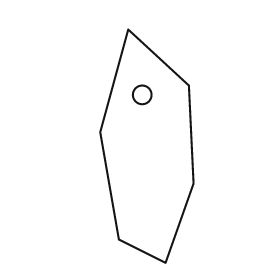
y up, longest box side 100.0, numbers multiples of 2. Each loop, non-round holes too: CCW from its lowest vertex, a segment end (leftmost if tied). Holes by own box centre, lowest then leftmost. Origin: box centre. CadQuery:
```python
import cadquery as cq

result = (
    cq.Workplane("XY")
    .moveTo(8.0, -50.0)
    .lineTo(20.0, -16.0)
    .lineTo(18.0, 26.0)
    .lineTo(-8.0, 50.0)
    .lineTo(-20.0, 6.0)
    .lineTo(-12.0, -40.0)
    .close()
    .moveTo(-2.0, 22.0)
    .circle(4.0)
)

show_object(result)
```